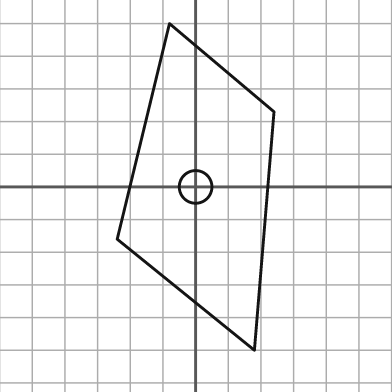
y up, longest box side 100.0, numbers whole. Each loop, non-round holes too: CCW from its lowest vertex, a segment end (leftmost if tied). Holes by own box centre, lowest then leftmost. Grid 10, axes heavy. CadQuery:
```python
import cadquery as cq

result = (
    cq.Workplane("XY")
    .moveTo(18.0, -50.0)
    .lineTo(24.0, 23.0)
    .lineTo(-8.0, 50.0)
    .lineTo(-24.0, -16.0)
    .close()
    .moveTo(0.0, 0.0)
    .circle(5.0)
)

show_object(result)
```